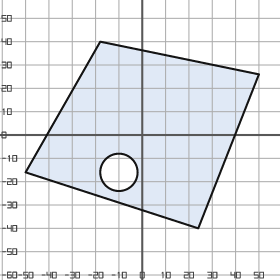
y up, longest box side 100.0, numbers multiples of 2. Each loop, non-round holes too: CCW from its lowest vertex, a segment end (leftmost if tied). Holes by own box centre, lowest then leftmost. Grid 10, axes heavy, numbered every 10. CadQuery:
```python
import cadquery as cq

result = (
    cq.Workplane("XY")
    .moveTo(24.0, -40.0)
    .lineTo(50.0, 26.0)
    .lineTo(-18.0, 40.0)
    .lineTo(-50.0, -16.0)
    .close()
    .moveTo(-10.0, -16.0)
    .circle(8.0)
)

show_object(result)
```